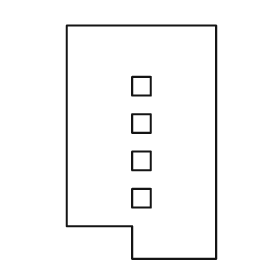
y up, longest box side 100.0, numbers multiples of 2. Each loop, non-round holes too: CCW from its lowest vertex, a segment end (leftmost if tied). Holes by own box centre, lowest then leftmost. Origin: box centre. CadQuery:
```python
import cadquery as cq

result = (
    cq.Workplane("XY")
    .moveTo(-4.0, -50.0)
    .lineTo(32.0, -50.0)
    .lineTo(32.0, 50.0)
    .lineTo(-32.0, 50.0)
    .lineTo(-32.0, -36.0)
    .lineTo(-4.0, -36.0)
    .close()
    .moveTo(-4.0, -28.0)
    .lineTo(4.0, -28.0)
    .lineTo(4.0, -20.0)
    .lineTo(-4.0, -20.0)
    .close()
    .moveTo(-4.0, -12.0)
    .lineTo(4.0, -12.0)
    .lineTo(4.0, -4.0)
    .lineTo(-4.0, -4.0)
    .close()
    .moveTo(-4.0, 4.0)
    .lineTo(4.0, 4.0)
    .lineTo(4.0, 12.0)
    .lineTo(-4.0, 12.0)
    .close()
    .moveTo(-4.0, 20.0)
    .lineTo(4.0, 20.0)
    .lineTo(4.0, 28.0)
    .lineTo(-4.0, 28.0)
    .close()
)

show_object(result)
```